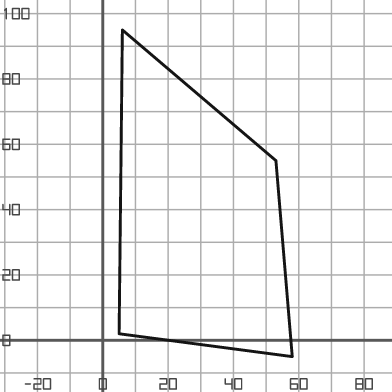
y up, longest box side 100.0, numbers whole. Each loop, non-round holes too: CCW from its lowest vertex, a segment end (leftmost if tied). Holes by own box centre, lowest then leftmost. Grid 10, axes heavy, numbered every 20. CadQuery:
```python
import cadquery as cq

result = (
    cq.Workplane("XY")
    .moveTo(58.0, -5.0)
    .lineTo(53.0, 55.0)
    .lineTo(6.0, 95.0)
    .lineTo(5.0, 2.0)
    .close()
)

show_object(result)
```